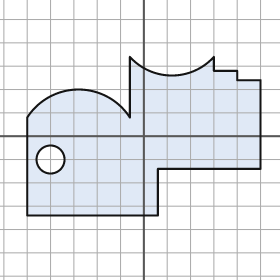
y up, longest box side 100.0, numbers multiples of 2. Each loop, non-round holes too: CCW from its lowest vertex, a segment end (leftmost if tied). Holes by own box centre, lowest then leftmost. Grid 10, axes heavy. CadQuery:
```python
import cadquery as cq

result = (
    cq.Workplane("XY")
    .moveTo(-50.0, -34.0)
    .lineTo(6.0, -34.0)
    .lineTo(6.0, -14.0)
    .lineTo(50.0, -14.0)
    .lineTo(50.0, 24.0)
    .lineTo(40.0, 24.0)
    .lineTo(40.0, 28.0)
    .lineTo(30.0, 28.0)
    .lineTo(30.0, 34.0)
    .threePointArc((12.0, 26.0), (-6.0, 34.0))
    .lineTo(-6.0, 8.0)
    .threePointArc((-28.0, 20.0), (-50.0, 8.0))
    .close()
    .moveTo(-40.0, -10.0)
    .circle(6.0)
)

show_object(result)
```